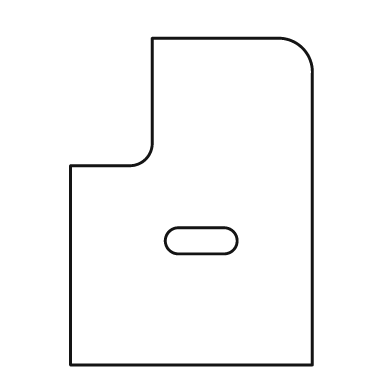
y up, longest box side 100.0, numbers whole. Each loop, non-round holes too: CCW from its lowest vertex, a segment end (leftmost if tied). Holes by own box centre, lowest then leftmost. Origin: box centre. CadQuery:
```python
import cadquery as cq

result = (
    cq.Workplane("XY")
    .moveTo(-37.0, -50.0)
    .lineTo(37.0, -50.0)
    .lineTo(37.0, 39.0)
    .threePointArc((34.0, 47.0), (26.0, 50.0))
    .lineTo(-12.0, 50.0)
    .lineTo(-12.0, 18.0)
    .threePointArc((-14.0, 13.0), (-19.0, 11.0))
    .lineTo(-37.0, 11.0)
    .close()
    .moveTo(-4.0, -16.0)
    .lineTo(10.0, -16.0)
    .threePointArc((14.0, -12.0), (10.0, -8.0))
    .lineTo(-4.0, -8.0)
    .threePointArc((-8.0, -12.0), (-4.0, -16.0))
    .close()
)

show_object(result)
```